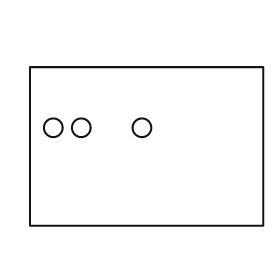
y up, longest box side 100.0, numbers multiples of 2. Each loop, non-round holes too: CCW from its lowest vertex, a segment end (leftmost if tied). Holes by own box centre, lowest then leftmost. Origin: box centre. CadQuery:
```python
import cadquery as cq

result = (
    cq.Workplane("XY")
    .moveTo(-50.0, -34.0)
    .lineTo(50.0, -34.0)
    .lineTo(50.0, 34.0)
    .lineTo(-50.0, 34.0)
    .close()
    .moveTo(-40.0, 8.0)
    .circle(4.0)
    .moveTo(-28.0, 8.0)
    .circle(4.0)
    .moveTo(-2.0, 8.0)
    .circle(4.0)
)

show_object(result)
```